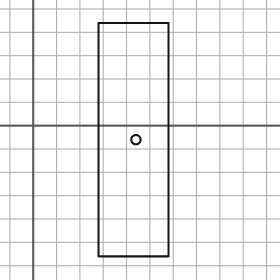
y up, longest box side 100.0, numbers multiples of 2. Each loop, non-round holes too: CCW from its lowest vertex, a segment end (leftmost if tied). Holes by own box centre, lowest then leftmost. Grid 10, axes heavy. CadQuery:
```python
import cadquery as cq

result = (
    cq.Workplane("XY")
    .moveTo(28.0, -56.0)
    .lineTo(58.0, -56.0)
    .lineTo(58.0, 44.0)
    .lineTo(28.0, 44.0)
    .close()
    .moveTo(44.0, -6.0)
    .circle(2.0)
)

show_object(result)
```